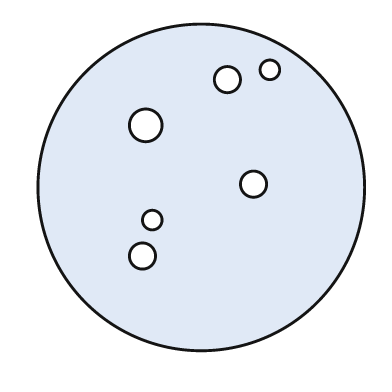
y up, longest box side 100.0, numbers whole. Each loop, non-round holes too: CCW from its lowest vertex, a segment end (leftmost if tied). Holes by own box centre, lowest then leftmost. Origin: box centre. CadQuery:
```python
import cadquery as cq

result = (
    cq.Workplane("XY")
    .moveTo(0.0, 0.0)
    .circle(50.0)
    .moveTo(-18.0, -21.0)
    .circle(4.0)
    .moveTo(-15.0, -10.0)
    .circle(3.0)
    .moveTo(16.0, 1.0)
    .circle(4.0)
    .moveTo(-17.0, 19.0)
    .circle(5.0)
    .moveTo(8.0, 33.0)
    .circle(4.0)
    .moveTo(21.0, 36.0)
    .circle(3.0)
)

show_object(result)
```